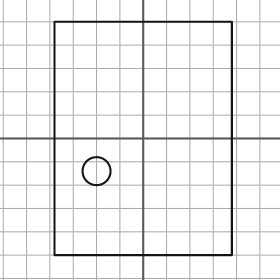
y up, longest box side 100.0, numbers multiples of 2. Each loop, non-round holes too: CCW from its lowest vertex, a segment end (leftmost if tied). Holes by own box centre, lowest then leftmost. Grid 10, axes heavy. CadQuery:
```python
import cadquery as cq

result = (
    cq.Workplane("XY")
    .moveTo(-38.0, -50.0)
    .lineTo(38.0, -50.0)
    .lineTo(38.0, 50.0)
    .lineTo(-38.0, 50.0)
    .close()
    .moveTo(-20.0, -14.0)
    .circle(6.0)
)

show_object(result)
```